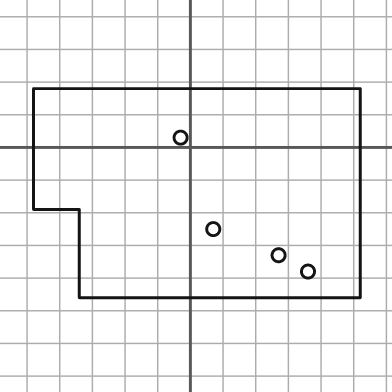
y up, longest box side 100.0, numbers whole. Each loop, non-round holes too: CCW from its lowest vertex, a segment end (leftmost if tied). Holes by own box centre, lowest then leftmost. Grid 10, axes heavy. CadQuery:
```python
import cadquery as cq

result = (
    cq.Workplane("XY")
    .moveTo(-34.0, -46.0)
    .lineTo(52.0, -46.0)
    .lineTo(52.0, 18.0)
    .lineTo(-48.0, 18.0)
    .lineTo(-48.0, -19.0)
    .lineTo(-34.0, -19.0)
    .close()
    .moveTo(36.0, -38.0)
    .circle(2.0)
    .moveTo(27.0, -33.0)
    .circle(2.0)
    .moveTo(7.0, -25.0)
    .circle(2.0)
    .moveTo(-3.0, 3.0)
    .circle(2.0)
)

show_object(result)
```